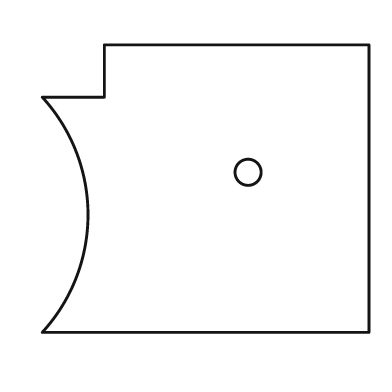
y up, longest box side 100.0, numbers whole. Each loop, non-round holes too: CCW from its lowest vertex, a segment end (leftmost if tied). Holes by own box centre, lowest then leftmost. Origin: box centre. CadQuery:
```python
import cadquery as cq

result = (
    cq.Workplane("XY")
    .moveTo(-50.0, -44.0)
    .lineTo(50.0, -44.0)
    .lineTo(50.0, 44.0)
    .lineTo(-31.0, 44.0)
    .lineTo(-31.0, 28.0)
    .lineTo(-50.0, 28.0)
    .threePointArc((-36.0, -8.0), (-50.0, -44.0))
    .close()
    .moveTo(13.0, 5.0)
    .circle(4.0)
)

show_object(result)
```